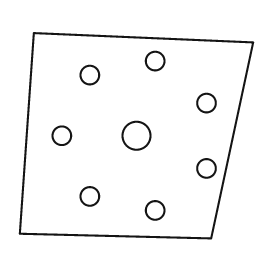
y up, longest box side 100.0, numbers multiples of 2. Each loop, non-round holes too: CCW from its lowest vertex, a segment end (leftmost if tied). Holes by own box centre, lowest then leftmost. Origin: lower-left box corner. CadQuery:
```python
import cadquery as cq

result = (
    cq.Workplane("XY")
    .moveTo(82.0, 0.0)
    .lineTo(100.0, 84.0)
    .lineTo(6.0, 88.0)
    .lineTo(0.0, 2.0)
    .close()
    .moveTo(58.0, 12.0)
    .circle(4.0)
    .moveTo(30.0, 18.0)
    .circle(4.0)
    .moveTo(80.0, 30.0)
    .circle(4.0)
    .moveTo(18.0, 44.0)
    .circle(4.0)
    .moveTo(50.0, 44.0)
    .circle(6.0)
    .moveTo(80.0, 58.0)
    .circle(4.0)
    .moveTo(30.0, 70.0)
    .circle(4.0)
    .moveTo(58.0, 76.0)
    .circle(4.0)
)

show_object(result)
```